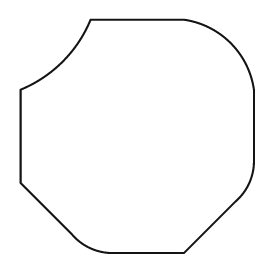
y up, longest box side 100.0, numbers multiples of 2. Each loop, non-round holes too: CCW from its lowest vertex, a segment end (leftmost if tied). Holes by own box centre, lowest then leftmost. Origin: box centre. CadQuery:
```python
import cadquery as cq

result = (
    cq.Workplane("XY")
    .moveTo(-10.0, -50.0)
    .lineTo(20.0, -50.0)
    .lineTo(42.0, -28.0)
    .threePointArc((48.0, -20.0), (50.0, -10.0))
    .lineTo(50.0, 20.0)
    .threePointArc((40.0, 40.0), (20.0, 50.0))
    .lineTo(-20.0, 50.0)
    .threePointArc((-32.0, 32.0), (-50.0, 20.0))
    .lineTo(-50.0, -20.0)
    .lineTo(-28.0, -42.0)
    .threePointArc((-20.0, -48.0), (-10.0, -50.0))
    .close()
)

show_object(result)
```